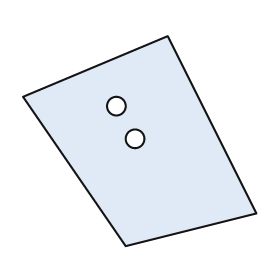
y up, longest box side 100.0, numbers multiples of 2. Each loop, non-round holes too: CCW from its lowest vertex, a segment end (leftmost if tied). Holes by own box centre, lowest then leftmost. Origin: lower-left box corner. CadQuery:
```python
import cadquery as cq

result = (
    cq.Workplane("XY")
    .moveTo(44.0, 0.0)
    .lineTo(100.0, 14.0)
    .lineTo(62.0, 90.0)
    .lineTo(0.0, 64.0)
    .close()
    .moveTo(48.0, 46.0)
    .circle(4.0)
    .moveTo(40.0, 60.0)
    .circle(4.0)
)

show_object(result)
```